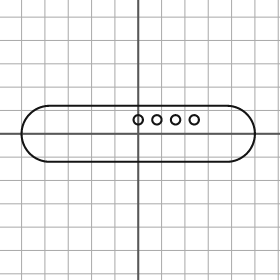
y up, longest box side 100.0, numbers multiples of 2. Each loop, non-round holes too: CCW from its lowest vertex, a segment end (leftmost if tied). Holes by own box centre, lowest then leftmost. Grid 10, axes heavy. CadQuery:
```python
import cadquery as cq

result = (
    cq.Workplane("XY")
    .moveTo(-38.0, -12.0)
    .lineTo(38.0, -12.0)
    .threePointArc((50.0, 0.0), (38.0, 12.0))
    .lineTo(-38.0, 12.0)
    .threePointArc((-50.0, 0.0), (-38.0, -12.0))
    .close()
    .moveTo(0.0, 6.0)
    .circle(2.0)
    .moveTo(8.0, 6.0)
    .circle(2.0)
    .moveTo(16.0, 6.0)
    .circle(2.0)
    .moveTo(24.0, 6.0)
    .circle(2.0)
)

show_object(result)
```